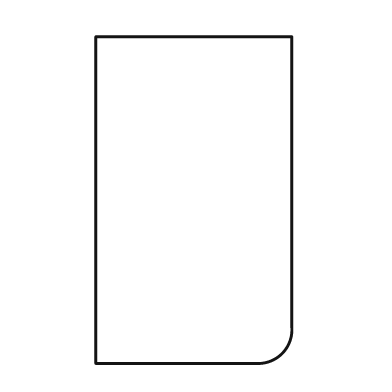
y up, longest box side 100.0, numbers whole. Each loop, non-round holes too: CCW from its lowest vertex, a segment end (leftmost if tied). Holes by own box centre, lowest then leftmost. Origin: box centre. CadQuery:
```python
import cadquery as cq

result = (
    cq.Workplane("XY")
    .moveTo(-30.0, -50.0)
    .lineTo(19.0, -50.0)
    .threePointArc((27.0, -47.0), (30.0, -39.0))
    .lineTo(30.0, 50.0)
    .lineTo(-30.0, 50.0)
    .close()
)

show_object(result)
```